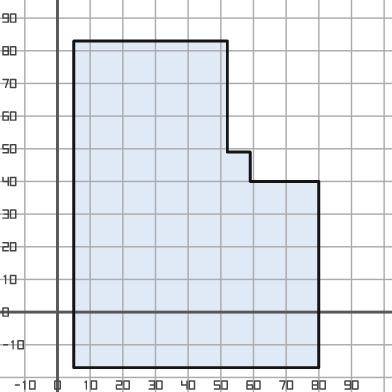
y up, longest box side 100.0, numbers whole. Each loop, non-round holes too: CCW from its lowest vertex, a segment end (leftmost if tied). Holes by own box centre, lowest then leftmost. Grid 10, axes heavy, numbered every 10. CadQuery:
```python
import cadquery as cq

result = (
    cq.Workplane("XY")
    .moveTo(5.0, -17.0)
    .lineTo(80.0, -17.0)
    .lineTo(80.0, 40.0)
    .lineTo(59.0, 40.0)
    .lineTo(59.0, 49.0)
    .lineTo(52.0, 49.0)
    .lineTo(52.0, 83.0)
    .lineTo(5.0, 83.0)
    .close()
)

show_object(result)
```